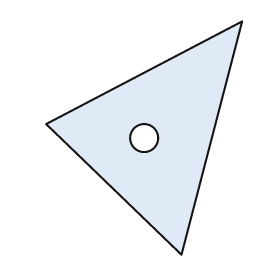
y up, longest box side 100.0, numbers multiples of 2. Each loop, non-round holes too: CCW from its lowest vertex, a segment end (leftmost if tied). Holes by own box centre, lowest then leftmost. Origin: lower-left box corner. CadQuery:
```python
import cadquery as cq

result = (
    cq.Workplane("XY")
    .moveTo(58.0, 0.0)
    .lineTo(84.0, 100.0)
    .lineTo(0.0, 56.0)
    .close()
    .moveTo(42.0, 50.0)
    .circle(6.0)
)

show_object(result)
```